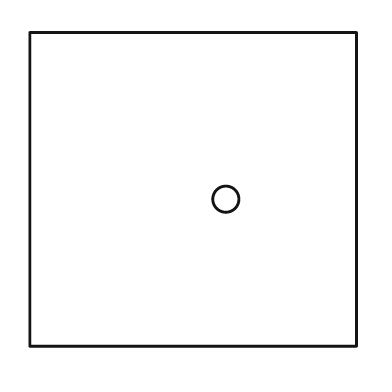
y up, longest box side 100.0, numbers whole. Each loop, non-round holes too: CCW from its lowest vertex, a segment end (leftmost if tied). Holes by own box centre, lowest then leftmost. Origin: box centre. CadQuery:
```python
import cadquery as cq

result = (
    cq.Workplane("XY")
    .moveTo(-50.0, -48.0)
    .lineTo(50.0, -48.0)
    .lineTo(50.0, 48.0)
    .lineTo(-50.0, 48.0)
    .close()
    .moveTo(10.0, -3.0)
    .circle(4.0)
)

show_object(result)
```